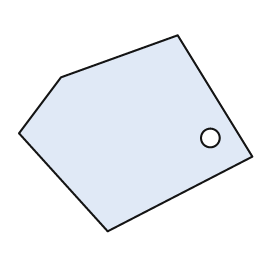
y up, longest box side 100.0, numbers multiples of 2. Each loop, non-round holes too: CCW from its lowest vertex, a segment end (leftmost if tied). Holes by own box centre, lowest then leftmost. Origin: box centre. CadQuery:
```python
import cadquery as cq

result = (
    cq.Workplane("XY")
    .moveTo(-12.0, -42.0)
    .lineTo(50.0, -10.0)
    .lineTo(18.0, 42.0)
    .lineTo(-32.0, 24.0)
    .lineTo(-50.0, 0.0)
    .close()
    .moveTo(32.0, -2.0)
    .circle(4.0)
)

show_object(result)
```